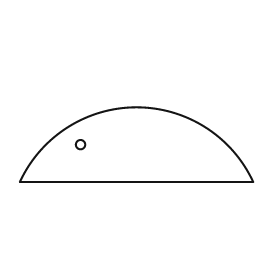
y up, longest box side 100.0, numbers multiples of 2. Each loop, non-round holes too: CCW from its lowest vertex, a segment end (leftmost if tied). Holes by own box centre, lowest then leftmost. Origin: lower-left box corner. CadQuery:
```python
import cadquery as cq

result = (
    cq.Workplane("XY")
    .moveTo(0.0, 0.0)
    .lineTo(100.0, 0.0)
    .threePointArc((50.0, 32.0), (0.0, 0.0))
    .close()
    .moveTo(26.0, 16.0)
    .circle(2.0)
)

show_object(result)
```